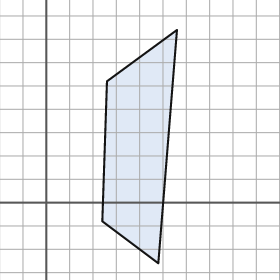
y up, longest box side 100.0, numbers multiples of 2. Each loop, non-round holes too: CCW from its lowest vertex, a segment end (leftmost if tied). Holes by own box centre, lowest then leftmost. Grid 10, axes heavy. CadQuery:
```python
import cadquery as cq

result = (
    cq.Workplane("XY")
    .moveTo(48.0, -26.0)
    .lineTo(56.0, 74.0)
    .lineTo(26.0, 52.0)
    .lineTo(24.0, -8.0)
    .close()
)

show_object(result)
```